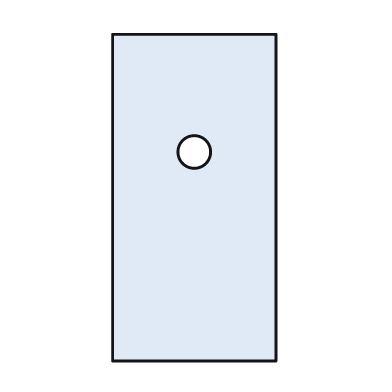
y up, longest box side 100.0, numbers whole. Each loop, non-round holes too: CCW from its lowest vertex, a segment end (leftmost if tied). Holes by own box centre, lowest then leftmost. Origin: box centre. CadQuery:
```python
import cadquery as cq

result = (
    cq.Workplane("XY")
    .moveTo(-25.0, -50.0)
    .lineTo(25.0, -50.0)
    .lineTo(25.0, 50.0)
    .lineTo(-25.0, 50.0)
    .close()
    .moveTo(0.0, 14.0)
    .circle(5.0)
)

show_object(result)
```